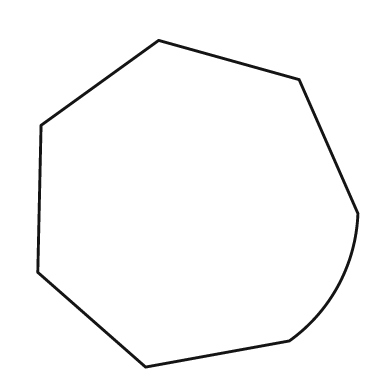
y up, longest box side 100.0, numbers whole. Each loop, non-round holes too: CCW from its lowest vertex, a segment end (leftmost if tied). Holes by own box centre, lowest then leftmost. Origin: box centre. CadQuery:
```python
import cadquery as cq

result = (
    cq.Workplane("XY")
    .moveTo(-16.0, -50.0)
    .lineTo(28.0, -42.0)
    .threePointArc((43.0, -25.0), (49.0, -3.0))
    .lineTo(31.0, 38.0)
    .lineTo(-12.0, 50.0)
    .lineTo(-48.0, 24.0)
    .lineTo(-49.0, -21.0)
    .close()
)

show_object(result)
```